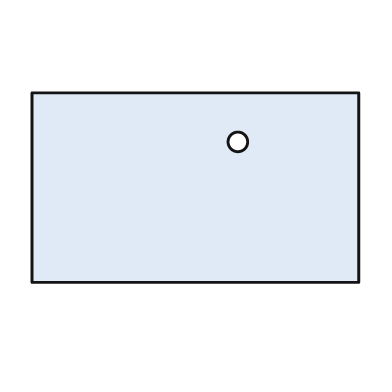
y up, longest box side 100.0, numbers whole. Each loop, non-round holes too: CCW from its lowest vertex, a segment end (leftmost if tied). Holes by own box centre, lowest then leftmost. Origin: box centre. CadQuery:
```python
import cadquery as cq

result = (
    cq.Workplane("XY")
    .moveTo(-50.0, -29.0)
    .lineTo(50.0, -29.0)
    .lineTo(50.0, 29.0)
    .lineTo(-50.0, 29.0)
    .close()
    .moveTo(13.0, 14.0)
    .circle(3.0)
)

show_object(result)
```